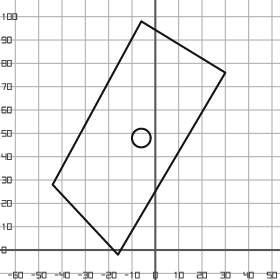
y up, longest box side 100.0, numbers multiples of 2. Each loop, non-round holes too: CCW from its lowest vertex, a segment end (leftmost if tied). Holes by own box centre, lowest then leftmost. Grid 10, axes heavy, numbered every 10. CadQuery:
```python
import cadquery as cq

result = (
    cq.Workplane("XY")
    .moveTo(-16.0, -2.0)
    .lineTo(30.0, 76.0)
    .lineTo(-6.0, 98.0)
    .lineTo(-44.0, 28.0)
    .close()
    .moveTo(-6.0, 48.0)
    .circle(4.0)
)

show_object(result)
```